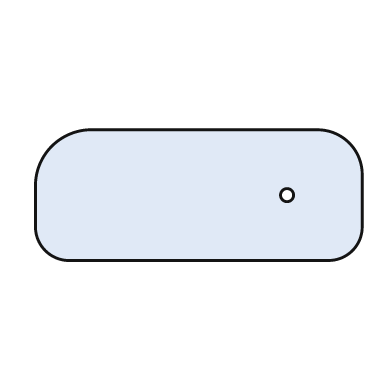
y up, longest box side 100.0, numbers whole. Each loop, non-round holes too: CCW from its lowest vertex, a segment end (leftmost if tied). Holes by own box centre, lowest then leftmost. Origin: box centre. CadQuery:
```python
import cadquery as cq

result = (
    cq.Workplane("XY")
    .moveTo(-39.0, -20.0)
    .lineTo(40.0, -20.0)
    .threePointArc((47.0, -17.0), (50.0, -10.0))
    .lineTo(50.0, 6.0)
    .threePointArc((46.0, 16.0), (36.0, 20.0))
    .lineTo(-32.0, 20.0)
    .threePointArc((-45.0, 15.0), (-50.0, 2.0))
    .lineTo(-50.0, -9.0)
    .threePointArc((-47.0, -17.0), (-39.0, -20.0))
    .close()
    .moveTo(27.0, 0.0)
    .circle(2.0)
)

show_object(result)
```